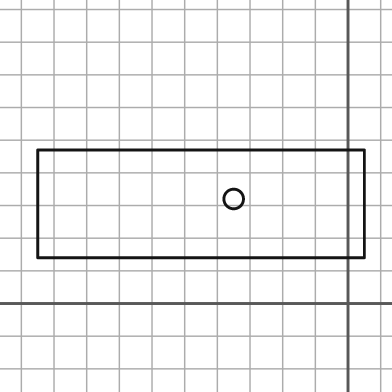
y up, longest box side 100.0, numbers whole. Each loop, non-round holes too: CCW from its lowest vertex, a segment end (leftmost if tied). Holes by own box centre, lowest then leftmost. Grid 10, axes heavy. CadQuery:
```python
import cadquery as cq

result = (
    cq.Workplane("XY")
    .moveTo(-95.0, 14.0)
    .lineTo(5.0, 14.0)
    .lineTo(5.0, 47.0)
    .lineTo(-95.0, 47.0)
    .close()
    .moveTo(-35.0, 32.0)
    .circle(3.0)
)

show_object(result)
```